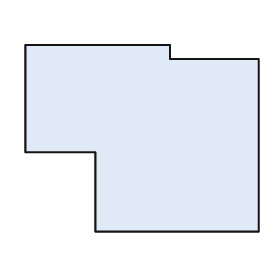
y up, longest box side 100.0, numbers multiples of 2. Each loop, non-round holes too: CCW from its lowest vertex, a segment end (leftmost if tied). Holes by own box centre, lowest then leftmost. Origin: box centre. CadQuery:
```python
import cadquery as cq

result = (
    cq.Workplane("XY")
    .moveTo(-20.0, -40.0)
    .lineTo(50.0, -40.0)
    .lineTo(50.0, 34.0)
    .lineTo(12.0, 34.0)
    .lineTo(12.0, 40.0)
    .lineTo(-50.0, 40.0)
    .lineTo(-50.0, -6.0)
    .lineTo(-20.0, -6.0)
    .close()
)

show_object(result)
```